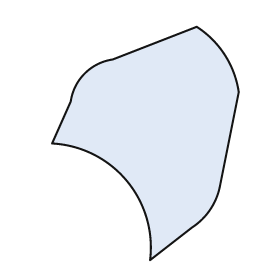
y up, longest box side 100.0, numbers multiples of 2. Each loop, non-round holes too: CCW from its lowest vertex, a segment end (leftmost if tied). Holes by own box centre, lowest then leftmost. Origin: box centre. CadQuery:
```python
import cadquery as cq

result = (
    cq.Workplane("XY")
    .moveTo(2.0, -50.0)
    .lineTo(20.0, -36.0)
    .threePointArc((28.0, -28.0), (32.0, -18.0))
    .lineTo(40.0, 22.0)
    .threePointArc((34.0, 38.0), (22.0, 50.0))
    .lineTo(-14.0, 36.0)
    .threePointArc((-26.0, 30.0), (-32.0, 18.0))
    .lineTo(-40.0, 0.0)
    .threePointArc((-8.0, -16.0), (2.0, -50.0))
    .close()
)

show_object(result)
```